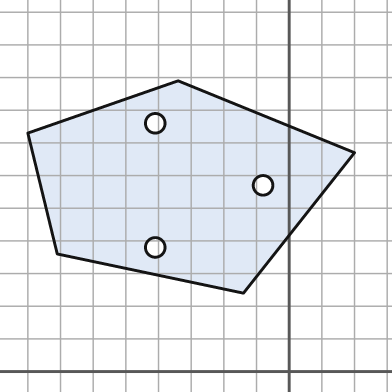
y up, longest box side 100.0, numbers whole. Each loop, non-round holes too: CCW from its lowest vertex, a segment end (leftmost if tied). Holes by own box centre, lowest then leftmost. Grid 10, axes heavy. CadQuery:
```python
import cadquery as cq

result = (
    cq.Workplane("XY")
    .moveTo(-14.0, 24.0)
    .lineTo(20.0, 67.0)
    .lineTo(-34.0, 89.0)
    .lineTo(-80.0, 73.0)
    .lineTo(-71.0, 36.0)
    .close()
    .moveTo(-41.0, 38.0)
    .circle(3.0)
    .moveTo(-8.0, 57.0)
    .circle(3.0)
    .moveTo(-41.0, 76.0)
    .circle(3.0)
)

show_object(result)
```